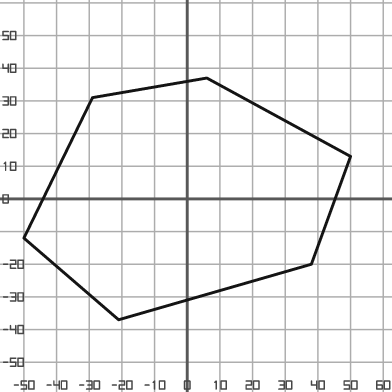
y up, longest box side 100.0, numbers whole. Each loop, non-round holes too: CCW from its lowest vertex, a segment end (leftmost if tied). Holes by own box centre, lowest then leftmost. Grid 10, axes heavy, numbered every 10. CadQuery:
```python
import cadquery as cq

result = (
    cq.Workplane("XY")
    .moveTo(-21.0, -37.0)
    .lineTo(38.0, -20.0)
    .lineTo(50.0, 13.0)
    .lineTo(6.0, 37.0)
    .lineTo(-29.0, 31.0)
    .lineTo(-50.0, -12.0)
    .close()
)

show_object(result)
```